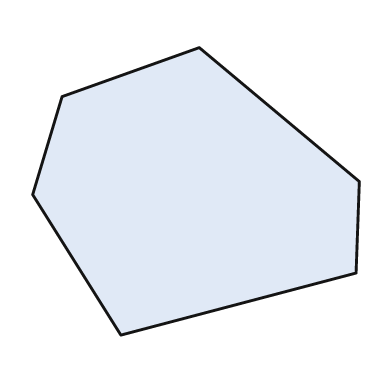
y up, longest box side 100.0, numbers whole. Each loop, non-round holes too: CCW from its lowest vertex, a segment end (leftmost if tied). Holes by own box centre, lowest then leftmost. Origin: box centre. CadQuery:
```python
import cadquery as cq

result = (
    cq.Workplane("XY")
    .moveTo(-23.0, -44.0)
    .lineTo(49.0, -25.0)
    .lineTo(50.0, 3.0)
    .lineTo(1.0, 44.0)
    .lineTo(-41.0, 29.0)
    .lineTo(-50.0, -1.0)
    .close()
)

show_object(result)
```